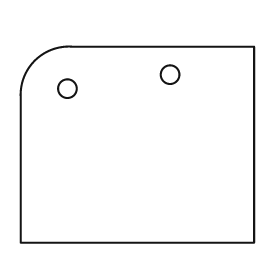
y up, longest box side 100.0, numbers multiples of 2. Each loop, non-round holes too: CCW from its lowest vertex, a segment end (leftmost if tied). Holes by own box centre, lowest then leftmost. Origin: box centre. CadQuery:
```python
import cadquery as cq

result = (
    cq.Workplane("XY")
    .moveTo(-50.0, -42.0)
    .lineTo(50.0, -42.0)
    .lineTo(50.0, 42.0)
    .lineTo(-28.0, 42.0)
    .threePointArc((-44.0, 36.0), (-50.0, 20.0))
    .close()
    .moveTo(-30.0, 24.0)
    .circle(4.0)
    .moveTo(14.0, 30.0)
    .circle(4.0)
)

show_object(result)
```